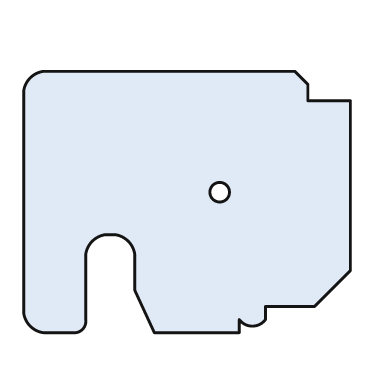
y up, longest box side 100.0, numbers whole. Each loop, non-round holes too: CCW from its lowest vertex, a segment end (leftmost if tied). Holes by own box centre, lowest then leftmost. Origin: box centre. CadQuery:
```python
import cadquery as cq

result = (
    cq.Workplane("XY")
    .moveTo(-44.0, -40.0)
    .lineTo(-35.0, -40.0)
    .threePointArc((-32.0, -39.0), (-31.0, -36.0))
    .lineTo(-31.0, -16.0)
    .threePointArc((-29.0, -12.0), (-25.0, -10.0))
    .lineTo(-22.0, -10.0)
    .threePointArc((-18.0, -12.0), (-16.0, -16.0))
    .lineTo(-16.0, -27.0)
    .lineTo(-10.0, -40.0)
    .lineTo(16.0, -40.0)
    .lineTo(16.0, -36.0)
    .threePointArc((20.0, -38.0), (24.0, -36.0))
    .lineTo(24.0, -32.0)
    .lineTo(39.0, -32.0)
    .lineTo(50.0, -21.0)
    .lineTo(50.0, 31.0)
    .lineTo(37.0, 31.0)
    .lineTo(37.0, 36.0)
    .lineTo(33.0, 40.0)
    .lineTo(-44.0, 40.0)
    .threePointArc((-48.0, 38.0), (-50.0, 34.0))
    .lineTo(-50.0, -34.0)
    .threePointArc((-48.0, -38.0), (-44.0, -40.0))
    .close()
    .moveTo(10.0, 3.0)
    .circle(3.0)
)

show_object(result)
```